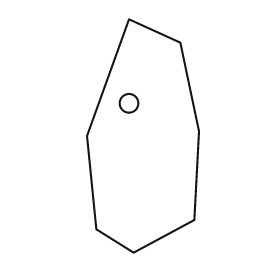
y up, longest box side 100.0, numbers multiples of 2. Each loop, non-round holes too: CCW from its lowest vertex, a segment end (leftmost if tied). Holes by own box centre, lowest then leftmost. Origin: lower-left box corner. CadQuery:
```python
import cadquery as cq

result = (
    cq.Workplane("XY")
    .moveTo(20.0, 0.0)
    .lineTo(46.0, 14.0)
    .lineTo(48.0, 52.0)
    .lineTo(40.0, 90.0)
    .lineTo(18.0, 100.0)
    .lineTo(0.0, 50.0)
    .lineTo(4.0, 10.0)
    .close()
    .moveTo(18.0, 64.0)
    .circle(4.0)
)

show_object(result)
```